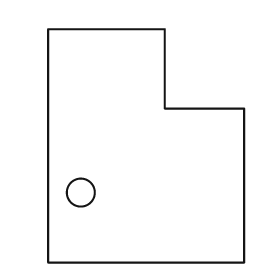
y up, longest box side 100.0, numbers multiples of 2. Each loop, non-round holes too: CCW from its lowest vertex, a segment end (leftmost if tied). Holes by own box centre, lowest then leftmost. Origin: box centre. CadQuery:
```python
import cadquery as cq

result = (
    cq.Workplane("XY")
    .moveTo(-42.0, -50.0)
    .lineTo(42.0, -50.0)
    .lineTo(42.0, 16.0)
    .lineTo(8.0, 16.0)
    .lineTo(8.0, 50.0)
    .lineTo(-42.0, 50.0)
    .close()
    .moveTo(-28.0, -20.0)
    .circle(6.0)
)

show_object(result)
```